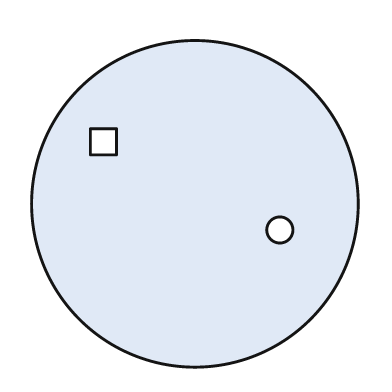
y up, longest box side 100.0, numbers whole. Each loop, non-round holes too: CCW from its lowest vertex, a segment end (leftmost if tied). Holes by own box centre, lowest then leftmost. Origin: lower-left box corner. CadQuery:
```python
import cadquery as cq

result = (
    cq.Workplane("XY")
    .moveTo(50.0, 50.0)
    .circle(50.0)
    .moveTo(76.0, 42.0)
    .circle(4.0)
    .moveTo(18.0, 65.0)
    .lineTo(26.0, 65.0)
    .lineTo(26.0, 73.0)
    .lineTo(18.0, 73.0)
    .close()
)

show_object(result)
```